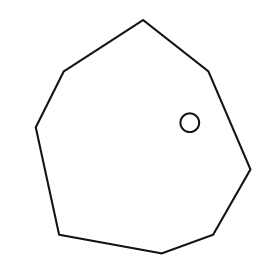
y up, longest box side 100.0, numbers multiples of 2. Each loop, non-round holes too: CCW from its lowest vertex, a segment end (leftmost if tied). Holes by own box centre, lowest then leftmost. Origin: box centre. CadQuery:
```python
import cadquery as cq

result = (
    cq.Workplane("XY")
    .moveTo(8.0, -50.0)
    .lineTo(30.0, -42.0)
    .lineTo(46.0, -14.0)
    .lineTo(28.0, 28.0)
    .lineTo(0.0, 50.0)
    .lineTo(-34.0, 28.0)
    .lineTo(-46.0, 4.0)
    .lineTo(-36.0, -42.0)
    .close()
    .moveTo(20.0, 6.0)
    .circle(4.0)
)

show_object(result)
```